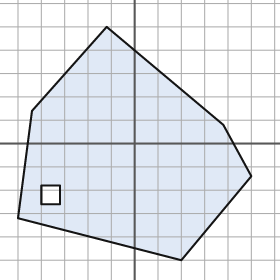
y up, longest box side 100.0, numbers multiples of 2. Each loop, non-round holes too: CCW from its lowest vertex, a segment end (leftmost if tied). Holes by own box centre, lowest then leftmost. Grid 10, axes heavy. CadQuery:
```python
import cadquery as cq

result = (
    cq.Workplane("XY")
    .moveTo(20.0, -50.0)
    .lineTo(50.0, -14.0)
    .lineTo(38.0, 8.0)
    .lineTo(-12.0, 50.0)
    .lineTo(-44.0, 14.0)
    .lineTo(-50.0, -32.0)
    .close()
    .moveTo(-40.0, -26.0)
    .lineTo(-32.0, -26.0)
    .lineTo(-32.0, -18.0)
    .lineTo(-40.0, -18.0)
    .close()
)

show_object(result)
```